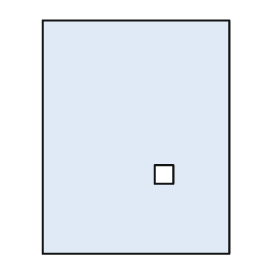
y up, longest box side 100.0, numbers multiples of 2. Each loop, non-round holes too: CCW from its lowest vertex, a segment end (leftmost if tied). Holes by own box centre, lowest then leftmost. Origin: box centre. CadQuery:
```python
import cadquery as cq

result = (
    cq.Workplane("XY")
    .moveTo(-40.0, -50.0)
    .lineTo(40.0, -50.0)
    .lineTo(40.0, 50.0)
    .lineTo(-40.0, 50.0)
    .close()
    .moveTo(8.0, -20.0)
    .lineTo(16.0, -20.0)
    .lineTo(16.0, -12.0)
    .lineTo(8.0, -12.0)
    .close()
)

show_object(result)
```